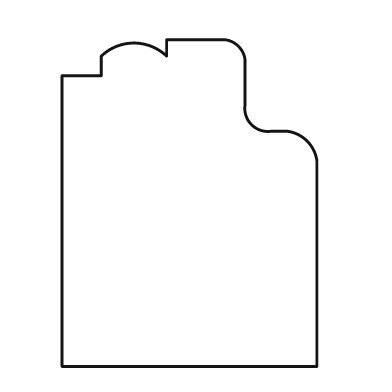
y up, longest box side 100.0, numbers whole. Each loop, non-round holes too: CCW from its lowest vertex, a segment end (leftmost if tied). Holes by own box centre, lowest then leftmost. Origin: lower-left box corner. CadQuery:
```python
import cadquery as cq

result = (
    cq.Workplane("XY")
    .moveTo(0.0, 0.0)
    .lineTo(78.0, 0.0)
    .lineTo(78.0, 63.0)
    .threePointArc((75.0, 69.0), (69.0, 72.0))
    .lineTo(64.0, 72.0)
    .threePointArc((58.0, 74.0), (56.0, 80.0))
    .lineTo(56.0, 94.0)
    .threePointArc((54.0, 98.0), (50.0, 100.0))
    .lineTo(32.0, 100.0)
    .lineTo(32.0, 95.0)
    .threePointArc((22.0, 99.0), (12.0, 95.0))
    .lineTo(12.0, 89.0)
    .lineTo(0.0, 89.0)
    .close()
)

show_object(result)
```